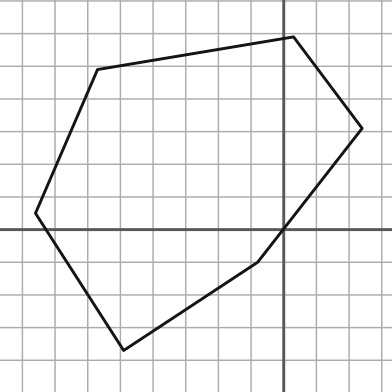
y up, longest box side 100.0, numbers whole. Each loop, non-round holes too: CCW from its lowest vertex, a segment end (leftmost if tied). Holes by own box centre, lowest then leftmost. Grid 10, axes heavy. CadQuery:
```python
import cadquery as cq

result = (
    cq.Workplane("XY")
    .moveTo(-49.0, -37.0)
    .lineTo(-8.0, -10.0)
    .lineTo(24.0, 31.0)
    .lineTo(3.0, 59.0)
    .lineTo(-57.0, 49.0)
    .lineTo(-76.0, 5.0)
    .close()
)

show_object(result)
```